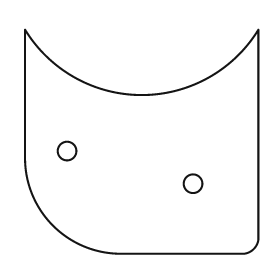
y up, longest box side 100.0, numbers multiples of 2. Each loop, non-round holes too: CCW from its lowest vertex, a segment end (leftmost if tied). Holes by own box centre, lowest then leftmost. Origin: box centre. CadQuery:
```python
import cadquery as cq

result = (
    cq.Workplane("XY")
    .moveTo(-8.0, -48.0)
    .lineTo(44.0, -48.0)
    .threePointArc((48.0, -46.0), (50.0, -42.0))
    .lineTo(50.0, 48.0)
    .threePointArc((0.0, 20.0), (-50.0, 48.0))
    .lineTo(-50.0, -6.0)
    .threePointArc((-38.0, -36.0), (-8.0, -48.0))
    .close()
    .moveTo(22.0, -18.0)
    .circle(4.0)
    .moveTo(-32.0, -4.0)
    .circle(4.0)
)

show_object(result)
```